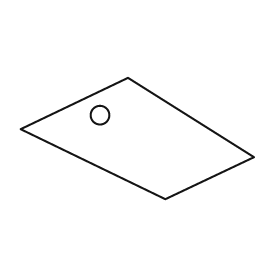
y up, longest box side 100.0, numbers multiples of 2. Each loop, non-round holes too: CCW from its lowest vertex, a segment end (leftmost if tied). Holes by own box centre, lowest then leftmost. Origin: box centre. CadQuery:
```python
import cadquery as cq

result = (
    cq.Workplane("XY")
    .moveTo(12.0, -26.0)
    .lineTo(50.0, -8.0)
    .lineTo(-4.0, 26.0)
    .lineTo(-50.0, 4.0)
    .close()
    .moveTo(-16.0, 10.0)
    .circle(4.0)
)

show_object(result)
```